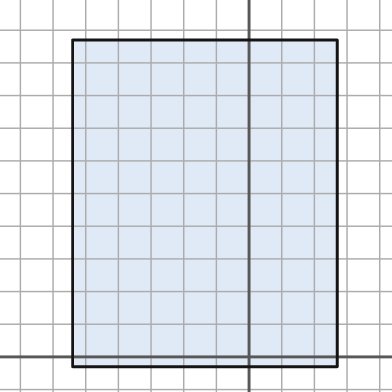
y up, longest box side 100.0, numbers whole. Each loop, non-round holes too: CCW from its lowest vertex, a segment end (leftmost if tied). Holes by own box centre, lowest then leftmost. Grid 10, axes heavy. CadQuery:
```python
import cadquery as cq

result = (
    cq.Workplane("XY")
    .moveTo(-54.0, -3.0)
    .lineTo(27.0, -3.0)
    .lineTo(27.0, 97.0)
    .lineTo(-54.0, 97.0)
    .close()
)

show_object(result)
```